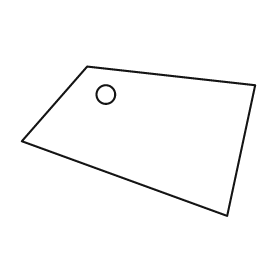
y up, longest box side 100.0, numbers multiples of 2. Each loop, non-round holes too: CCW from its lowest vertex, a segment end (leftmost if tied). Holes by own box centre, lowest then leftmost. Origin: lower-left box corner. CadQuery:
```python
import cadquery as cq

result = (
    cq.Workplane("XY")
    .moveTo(88.0, 0.0)
    .lineTo(100.0, 56.0)
    .lineTo(28.0, 64.0)
    .lineTo(0.0, 32.0)
    .close()
    .moveTo(36.0, 52.0)
    .circle(4.0)
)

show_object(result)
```